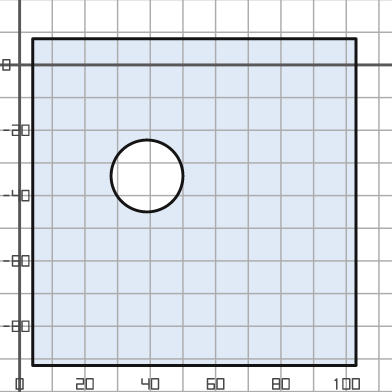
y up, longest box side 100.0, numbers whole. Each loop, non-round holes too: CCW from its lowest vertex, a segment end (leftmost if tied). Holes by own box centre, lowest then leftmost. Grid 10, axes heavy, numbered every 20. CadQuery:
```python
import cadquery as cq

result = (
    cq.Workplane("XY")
    .moveTo(4.0, -92.0)
    .lineTo(103.0, -92.0)
    .lineTo(103.0, 8.0)
    .lineTo(4.0, 8.0)
    .close()
    .moveTo(39.0, -34.0)
    .circle(11.0)
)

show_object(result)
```